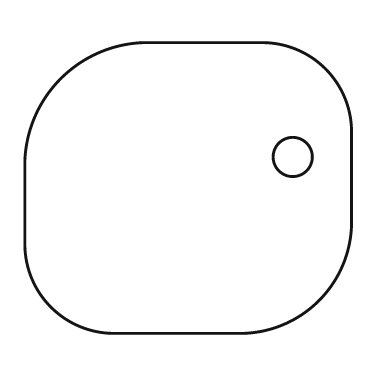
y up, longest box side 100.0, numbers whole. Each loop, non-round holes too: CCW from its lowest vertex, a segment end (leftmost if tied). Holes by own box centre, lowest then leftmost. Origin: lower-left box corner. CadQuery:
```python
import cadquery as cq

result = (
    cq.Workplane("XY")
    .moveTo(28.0, 0.0)
    .lineTo(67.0, 0.0)
    .threePointArc((90.0, 10.0), (100.0, 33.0))
    .lineTo(100.0, 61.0)
    .threePointArc((92.0, 81.0), (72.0, 89.0))
    .lineTo(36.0, 89.0)
    .threePointArc((11.0, 78.0), (0.0, 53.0))
    .lineTo(0.0, 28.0)
    .threePointArc((8.0, 8.0), (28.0, 0.0))
    .close()
    .moveTo(82.0, 54.0)
    .circle(6.0)
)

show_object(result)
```